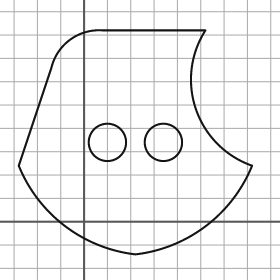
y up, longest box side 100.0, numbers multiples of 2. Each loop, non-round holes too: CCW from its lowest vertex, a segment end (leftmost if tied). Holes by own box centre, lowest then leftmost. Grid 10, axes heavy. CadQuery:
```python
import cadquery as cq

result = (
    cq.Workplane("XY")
    .moveTo(22.0, -14.0)
    .threePointArc((52.0, -2.0), (72.0, 24.0))
    .threePointArc((48.0, 48.0), (52.0, 82.0))
    .lineTo(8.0, 82.0)
    .threePointArc((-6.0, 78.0), (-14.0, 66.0))
    .lineTo(-28.0, 24.0)
    .threePointArc((-8.0, -2.0), (22.0, -14.0))
    .close()
    .moveTo(10.0, 34.0)
    .circle(8.0)
    .moveTo(34.0, 34.0)
    .circle(8.0)
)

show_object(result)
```